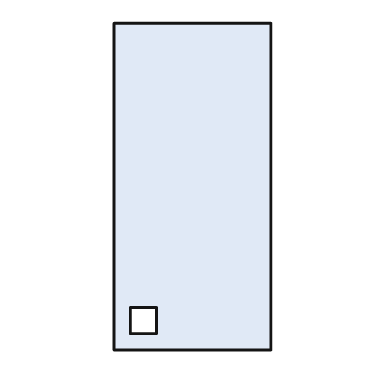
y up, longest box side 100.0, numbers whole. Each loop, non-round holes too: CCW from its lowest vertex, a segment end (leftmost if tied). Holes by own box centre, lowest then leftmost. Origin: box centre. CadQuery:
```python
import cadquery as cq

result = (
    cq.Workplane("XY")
    .moveTo(-24.0, -50.0)
    .lineTo(24.0, -50.0)
    .lineTo(24.0, 50.0)
    .lineTo(-24.0, 50.0)
    .close()
    .moveTo(-19.0, -45.0)
    .lineTo(-11.0, -45.0)
    .lineTo(-11.0, -37.0)
    .lineTo(-19.0, -37.0)
    .close()
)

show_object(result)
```